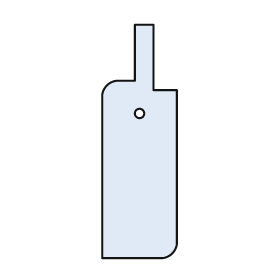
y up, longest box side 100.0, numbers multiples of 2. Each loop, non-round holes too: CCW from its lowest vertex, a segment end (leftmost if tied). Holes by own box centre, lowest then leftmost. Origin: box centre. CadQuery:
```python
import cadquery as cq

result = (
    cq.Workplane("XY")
    .moveTo(-16.0, -50.0)
    .lineTo(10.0, -50.0)
    .threePointArc((14.0, -48.0), (16.0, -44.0))
    .lineTo(16.0, 22.0)
    .lineTo(6.0, 22.0)
    .lineTo(6.0, 50.0)
    .lineTo(-2.0, 50.0)
    .lineTo(-2.0, 26.0)
    .lineTo(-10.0, 26.0)
    .threePointArc((-14.0, 24.0), (-16.0, 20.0))
    .close()
    .moveTo(0.0, 12.0)
    .circle(2.0)
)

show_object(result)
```